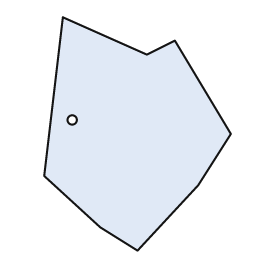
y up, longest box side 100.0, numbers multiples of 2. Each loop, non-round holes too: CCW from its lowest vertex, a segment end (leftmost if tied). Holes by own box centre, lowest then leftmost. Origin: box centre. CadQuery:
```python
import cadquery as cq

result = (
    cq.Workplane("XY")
    .moveTo(0.0, -50.0)
    .lineTo(26.0, -22.0)
    .lineTo(40.0, 0.0)
    .lineTo(16.0, 40.0)
    .lineTo(4.0, 34.0)
    .lineTo(-32.0, 50.0)
    .lineTo(-40.0, -18.0)
    .lineTo(-16.0, -40.0)
    .close()
    .moveTo(-28.0, 6.0)
    .circle(2.0)
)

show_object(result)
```